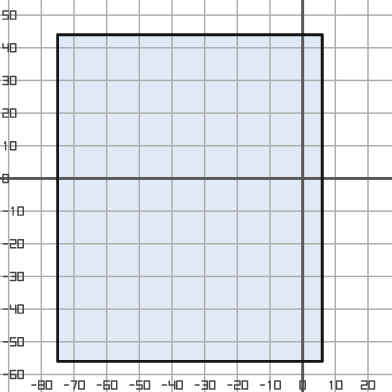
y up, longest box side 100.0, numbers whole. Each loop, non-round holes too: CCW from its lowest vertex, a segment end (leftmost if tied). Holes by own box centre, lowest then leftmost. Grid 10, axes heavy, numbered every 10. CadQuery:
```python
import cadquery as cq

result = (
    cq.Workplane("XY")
    .moveTo(-75.0, -56.0)
    .lineTo(6.0, -56.0)
    .lineTo(6.0, 44.0)
    .lineTo(-75.0, 44.0)
    .close()
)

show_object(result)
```